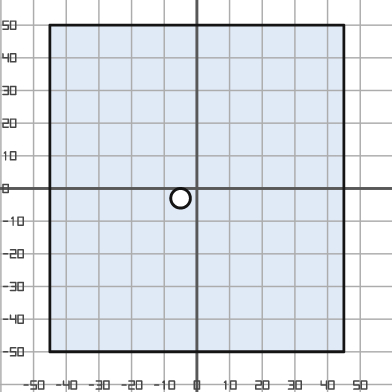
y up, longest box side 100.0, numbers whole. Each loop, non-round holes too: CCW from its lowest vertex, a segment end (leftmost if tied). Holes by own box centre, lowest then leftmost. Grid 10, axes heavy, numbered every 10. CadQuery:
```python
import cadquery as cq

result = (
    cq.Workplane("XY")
    .moveTo(-45.0, -50.0)
    .lineTo(45.0, -50.0)
    .lineTo(45.0, 50.0)
    .lineTo(-45.0, 50.0)
    .close()
    .moveTo(-5.0, -3.0)
    .circle(3.0)
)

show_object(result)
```